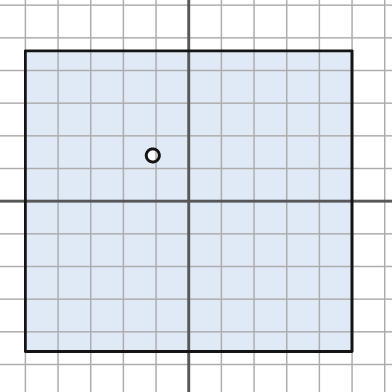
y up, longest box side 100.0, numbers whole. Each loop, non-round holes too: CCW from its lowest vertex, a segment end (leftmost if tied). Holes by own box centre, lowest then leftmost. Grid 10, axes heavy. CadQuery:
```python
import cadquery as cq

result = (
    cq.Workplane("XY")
    .moveTo(-50.0, -46.0)
    .lineTo(50.0, -46.0)
    .lineTo(50.0, 46.0)
    .lineTo(-50.0, 46.0)
    .close()
    .moveTo(-11.0, 14.0)
    .circle(2.0)
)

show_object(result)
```